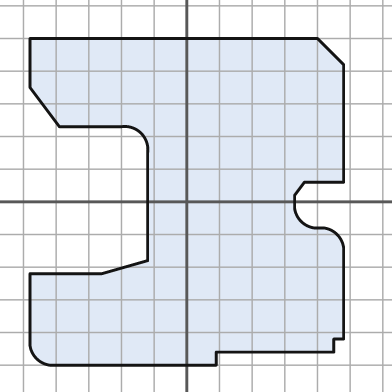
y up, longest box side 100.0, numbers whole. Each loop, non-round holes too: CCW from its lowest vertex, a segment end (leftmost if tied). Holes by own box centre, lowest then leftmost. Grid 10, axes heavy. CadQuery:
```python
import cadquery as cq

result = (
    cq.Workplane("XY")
    .moveTo(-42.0, -50.0)
    .lineTo(9.0, -50.0)
    .lineTo(9.0, -46.0)
    .lineTo(45.0, -46.0)
    .lineTo(45.0, -42.0)
    .lineTo(48.0, -42.0)
    .lineTo(48.0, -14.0)
    .threePointArc((46.0, -10.0), (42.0, -8.0))
    .lineTo(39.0, -8.0)
    .threePointArc((35.0, -6.0), (33.0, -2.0))
    .lineTo(33.0, 2.0)
    .lineTo(36.0, 6.0)
    .lineTo(48.0, 6.0)
    .lineTo(48.0, 42.0)
    .lineTo(40.0, 50.0)
    .lineTo(-48.0, 50.0)
    .lineTo(-48.0, 35.0)
    .lineTo(-39.0, 23.0)
    .lineTo(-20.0, 23.0)
    .threePointArc((-14.0, 21.0), (-12.0, 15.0))
    .lineTo(-12.0, -18.0)
    .lineTo(-26.0, -22.0)
    .lineTo(-48.0, -22.0)
    .lineTo(-48.0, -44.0)
    .threePointArc((-46.0, -48.0), (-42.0, -50.0))
    .close()
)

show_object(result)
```